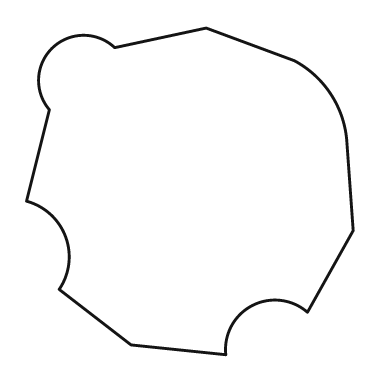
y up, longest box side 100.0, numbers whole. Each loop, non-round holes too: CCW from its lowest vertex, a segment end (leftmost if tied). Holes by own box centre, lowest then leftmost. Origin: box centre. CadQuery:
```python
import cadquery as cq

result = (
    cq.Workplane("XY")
    .moveTo(11.0, -50.0)
    .threePointArc((19.0, -35.0), (36.0, -37.0))
    .lineTo(50.0, -12.0)
    .lineTo(48.0, 16.0)
    .threePointArc((43.0, 30.0), (32.0, 40.0))
    .lineTo(5.0, 50.0)
    .lineTo(-23.0, 44.0)
    .threePointArc((-42.0, 44.0), (-43.0, 25.0))
    .lineTo(-50.0, -3.0)
    .threePointArc((-38.0, -14.0), (-40.0, -30.0))
    .lineTo(-18.0, -47.0)
    .close()
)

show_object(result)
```